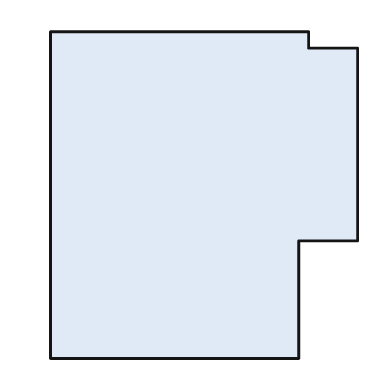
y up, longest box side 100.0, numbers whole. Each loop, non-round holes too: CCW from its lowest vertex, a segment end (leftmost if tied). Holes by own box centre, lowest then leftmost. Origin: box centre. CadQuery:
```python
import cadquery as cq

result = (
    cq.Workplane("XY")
    .moveTo(-47.0, -50.0)
    .lineTo(29.0, -50.0)
    .lineTo(29.0, -14.0)
    .lineTo(47.0, -14.0)
    .lineTo(47.0, 45.0)
    .lineTo(32.0, 45.0)
    .lineTo(32.0, 50.0)
    .lineTo(-47.0, 50.0)
    .close()
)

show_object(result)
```